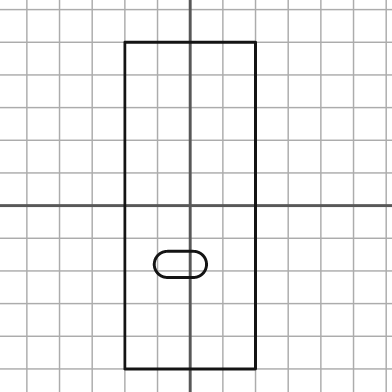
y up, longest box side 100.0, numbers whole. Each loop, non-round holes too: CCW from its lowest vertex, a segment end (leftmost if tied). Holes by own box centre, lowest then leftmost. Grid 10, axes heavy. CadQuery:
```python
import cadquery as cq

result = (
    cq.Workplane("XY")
    .moveTo(-20.0, -50.0)
    .lineTo(20.0, -50.0)
    .lineTo(20.0, 50.0)
    .lineTo(-20.0, 50.0)
    .close()
    .moveTo(-7.0, -22.0)
    .lineTo(1.0, -22.0)
    .threePointArc((5.0, -18.0), (1.0, -14.0))
    .lineTo(-7.0, -14.0)
    .threePointArc((-11.0, -18.0), (-7.0, -22.0))
    .close()
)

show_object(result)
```